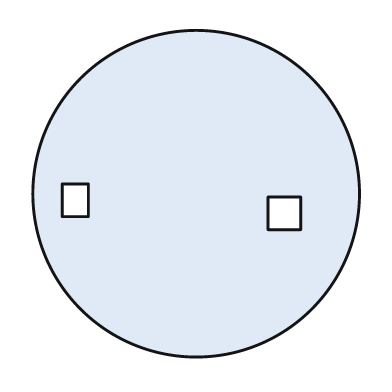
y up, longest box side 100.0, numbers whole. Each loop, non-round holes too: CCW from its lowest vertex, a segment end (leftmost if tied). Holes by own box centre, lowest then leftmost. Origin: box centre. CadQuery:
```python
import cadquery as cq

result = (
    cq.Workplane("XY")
    .moveTo(0.0, 0.0)
    .circle(50.0)
    .moveTo(22.0, -11.0)
    .lineTo(32.0, -11.0)
    .lineTo(32.0, -1.0)
    .lineTo(22.0, -1.0)
    .close()
    .moveTo(-41.0, -7.0)
    .lineTo(-33.0, -7.0)
    .lineTo(-33.0, 3.0)
    .lineTo(-41.0, 3.0)
    .close()
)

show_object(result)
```